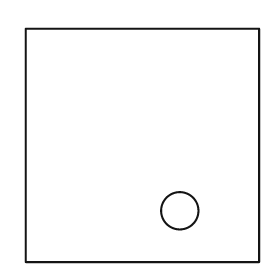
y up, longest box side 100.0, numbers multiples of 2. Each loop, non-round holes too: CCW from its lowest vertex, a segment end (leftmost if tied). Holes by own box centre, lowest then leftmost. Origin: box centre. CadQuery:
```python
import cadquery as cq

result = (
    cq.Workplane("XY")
    .moveTo(-50.0, -50.0)
    .lineTo(50.0, -50.0)
    .lineTo(50.0, 50.0)
    .lineTo(-50.0, 50.0)
    .close()
    .moveTo(16.0, -28.0)
    .circle(8.0)
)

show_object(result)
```